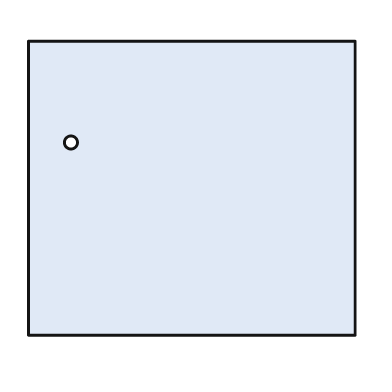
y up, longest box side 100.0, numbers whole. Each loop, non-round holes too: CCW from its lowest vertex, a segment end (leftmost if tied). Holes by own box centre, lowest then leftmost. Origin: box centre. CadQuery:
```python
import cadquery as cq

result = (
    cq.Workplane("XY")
    .moveTo(-50.0, -45.0)
    .lineTo(50.0, -45.0)
    .lineTo(50.0, 45.0)
    .lineTo(-50.0, 45.0)
    .close()
    .moveTo(-37.0, 14.0)
    .circle(2.0)
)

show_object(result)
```